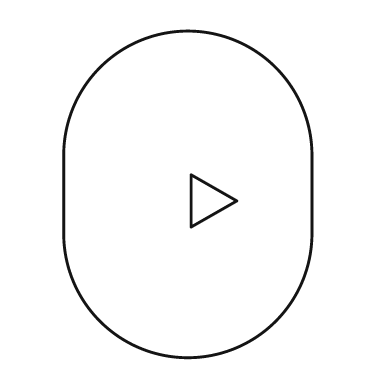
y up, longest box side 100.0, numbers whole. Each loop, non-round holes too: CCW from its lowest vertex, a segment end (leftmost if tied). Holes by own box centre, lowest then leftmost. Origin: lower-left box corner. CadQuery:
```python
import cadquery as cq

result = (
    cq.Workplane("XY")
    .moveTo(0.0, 38.0)
    .threePointArc((38.0, 0.0), (76.0, 38.0))
    .lineTo(76.0, 62.0)
    .threePointArc((38.0, 100.0), (0.0, 62.0))
    .close()
    .moveTo(39.0, 40.0)
    .lineTo(53.0, 48.0)
    .lineTo(39.0, 56.0)
    .close()
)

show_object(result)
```